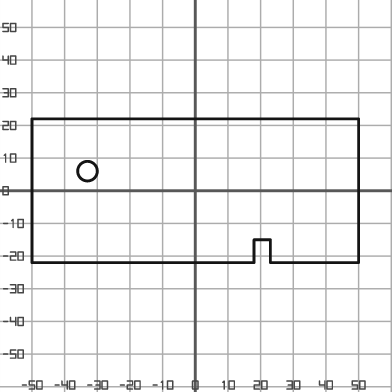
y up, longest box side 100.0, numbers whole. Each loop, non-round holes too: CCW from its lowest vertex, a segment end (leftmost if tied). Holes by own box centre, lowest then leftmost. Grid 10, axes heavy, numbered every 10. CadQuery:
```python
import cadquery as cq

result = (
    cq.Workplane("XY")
    .moveTo(-50.0, -22.0)
    .lineTo(18.0, -22.0)
    .lineTo(18.0, -15.0)
    .lineTo(23.0, -15.0)
    .lineTo(23.0, -22.0)
    .lineTo(50.0, -22.0)
    .lineTo(50.0, 22.0)
    .lineTo(-50.0, 22.0)
    .close()
    .moveTo(-33.0, 6.0)
    .circle(3.0)
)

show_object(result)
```